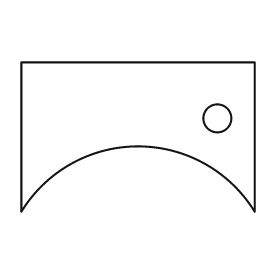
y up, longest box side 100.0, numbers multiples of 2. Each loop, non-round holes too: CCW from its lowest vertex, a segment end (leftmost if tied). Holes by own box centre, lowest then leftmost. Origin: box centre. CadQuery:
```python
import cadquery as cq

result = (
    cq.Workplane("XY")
    .moveTo(-50.0, -32.0)
    .threePointArc((0.0, -4.0), (50.0, -32.0))
    .lineTo(50.0, 32.0)
    .lineTo(-50.0, 32.0)
    .close()
    .moveTo(34.0, 8.0)
    .circle(6.0)
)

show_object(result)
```